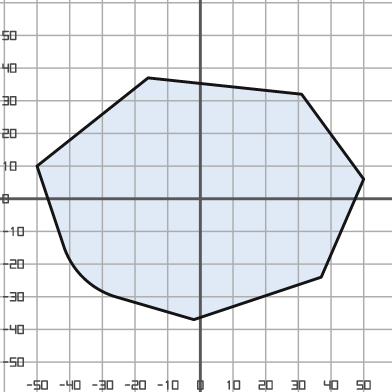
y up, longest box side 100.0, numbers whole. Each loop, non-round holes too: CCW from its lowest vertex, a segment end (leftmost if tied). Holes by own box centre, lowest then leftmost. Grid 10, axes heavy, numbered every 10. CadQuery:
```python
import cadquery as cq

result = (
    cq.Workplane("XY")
    .moveTo(-2.0, -37.0)
    .lineTo(37.0, -24.0)
    .lineTo(50.0, 6.0)
    .lineTo(31.0, 32.0)
    .lineTo(-16.0, 37.0)
    .lineTo(-50.0, 10.0)
    .lineTo(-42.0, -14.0)
    .threePointArc((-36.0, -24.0), (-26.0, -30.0))
    .close()
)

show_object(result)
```